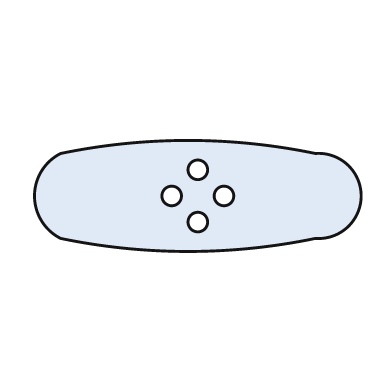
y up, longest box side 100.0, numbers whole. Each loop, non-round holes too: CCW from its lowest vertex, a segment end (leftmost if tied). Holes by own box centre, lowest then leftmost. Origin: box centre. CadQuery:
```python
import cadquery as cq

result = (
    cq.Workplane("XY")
    .moveTo(-42.0, -13.0)
    .threePointArc((-3.0, -17.0), (36.0, -13.0))
    .threePointArc((50.0, 0.0), (36.0, 13.0))
    .threePointArc((-3.0, 17.0), (-42.0, 13.0))
    .threePointArc((-50.0, 0.0), (-42.0, -13.0))
    .close()
    .moveTo(0.0, -8.0)
    .circle(3.0)
    .moveTo(-8.0, 0.0)
    .circle(3.0)
    .moveTo(8.0, 0.0)
    .circle(3.0)
    .moveTo(0.0, 8.0)
    .circle(3.0)
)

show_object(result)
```